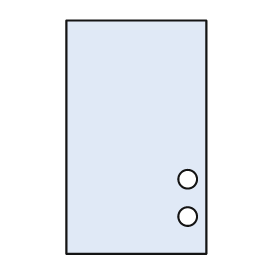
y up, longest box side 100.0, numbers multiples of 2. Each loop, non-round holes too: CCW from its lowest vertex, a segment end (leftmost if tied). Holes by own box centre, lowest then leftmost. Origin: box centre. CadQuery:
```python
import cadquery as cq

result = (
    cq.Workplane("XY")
    .moveTo(-30.0, -50.0)
    .lineTo(30.0, -50.0)
    .lineTo(30.0, 50.0)
    .lineTo(-30.0, 50.0)
    .close()
    .moveTo(22.0, -34.0)
    .circle(4.0)
    .moveTo(22.0, -18.0)
    .circle(4.0)
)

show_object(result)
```